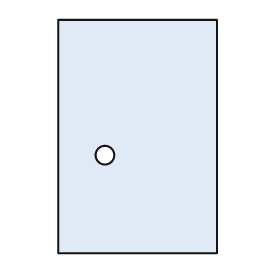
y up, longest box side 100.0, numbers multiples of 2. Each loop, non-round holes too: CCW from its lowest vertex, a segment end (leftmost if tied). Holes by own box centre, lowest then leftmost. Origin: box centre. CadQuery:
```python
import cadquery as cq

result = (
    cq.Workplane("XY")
    .moveTo(-34.0, -50.0)
    .lineTo(34.0, -50.0)
    .lineTo(34.0, 50.0)
    .lineTo(-34.0, 50.0)
    .close()
    .moveTo(-14.0, -8.0)
    .circle(4.0)
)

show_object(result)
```